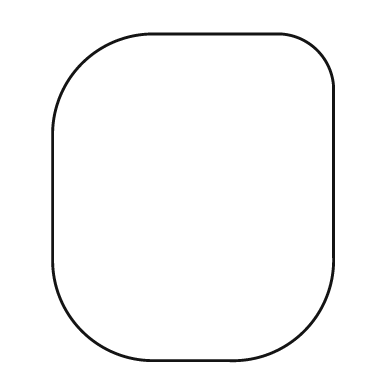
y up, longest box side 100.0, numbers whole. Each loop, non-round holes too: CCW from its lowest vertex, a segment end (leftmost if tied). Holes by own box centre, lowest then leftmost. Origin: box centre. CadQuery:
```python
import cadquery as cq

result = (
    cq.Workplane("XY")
    .moveTo(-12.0, -50.0)
    .lineTo(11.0, -50.0)
    .threePointArc((34.0, -41.0), (43.0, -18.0))
    .lineTo(43.0, 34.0)
    .threePointArc((38.0, 45.0), (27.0, 50.0))
    .lineTo(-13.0, 50.0)
    .threePointArc((-34.0, 41.0), (-43.0, 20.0))
    .lineTo(-43.0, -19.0)
    .threePointArc((-34.0, -41.0), (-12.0, -50.0))
    .close()
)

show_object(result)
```